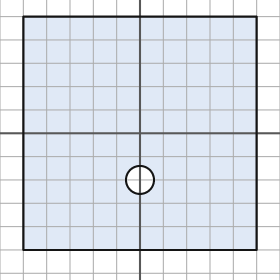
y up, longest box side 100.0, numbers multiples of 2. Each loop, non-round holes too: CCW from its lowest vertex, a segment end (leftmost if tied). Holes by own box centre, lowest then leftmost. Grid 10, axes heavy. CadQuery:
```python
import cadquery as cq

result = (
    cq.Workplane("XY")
    .moveTo(-50.0, -50.0)
    .lineTo(50.0, -50.0)
    .lineTo(50.0, 50.0)
    .lineTo(-50.0, 50.0)
    .close()
    .moveTo(0.0, -20.0)
    .circle(6.0)
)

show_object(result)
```